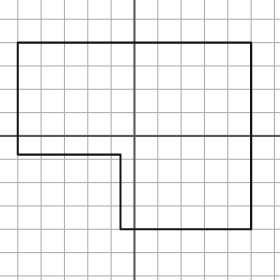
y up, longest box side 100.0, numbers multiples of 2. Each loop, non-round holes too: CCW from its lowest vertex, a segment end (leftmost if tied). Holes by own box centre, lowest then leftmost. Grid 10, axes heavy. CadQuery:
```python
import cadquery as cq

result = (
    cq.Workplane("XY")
    .moveTo(-6.0, -40.0)
    .lineTo(50.0, -40.0)
    .lineTo(50.0, 40.0)
    .lineTo(-50.0, 40.0)
    .lineTo(-50.0, -8.0)
    .lineTo(-6.0, -8.0)
    .close()
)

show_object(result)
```